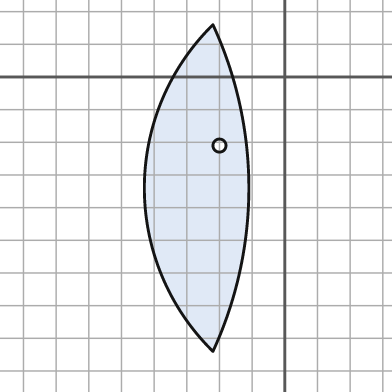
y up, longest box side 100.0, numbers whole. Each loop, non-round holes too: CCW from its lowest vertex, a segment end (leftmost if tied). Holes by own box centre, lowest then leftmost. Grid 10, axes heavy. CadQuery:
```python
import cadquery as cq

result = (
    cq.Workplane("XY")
    .moveTo(-22.0, -84.0)
    .threePointArc((-11.0, -34.0), (-22.0, 16.0))
    .threePointArc((-43.0, -34.0), (-22.0, -84.0))
    .close()
    .moveTo(-20.0, -21.0)
    .circle(2.0)
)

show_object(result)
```